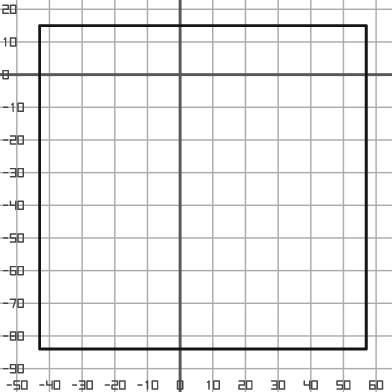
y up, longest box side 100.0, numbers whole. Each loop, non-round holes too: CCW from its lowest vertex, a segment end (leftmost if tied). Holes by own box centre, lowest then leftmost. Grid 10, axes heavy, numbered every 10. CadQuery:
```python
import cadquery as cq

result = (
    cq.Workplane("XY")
    .moveTo(-43.0, -84.0)
    .lineTo(57.0, -84.0)
    .lineTo(57.0, 15.0)
    .lineTo(-43.0, 15.0)
    .close()
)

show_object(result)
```